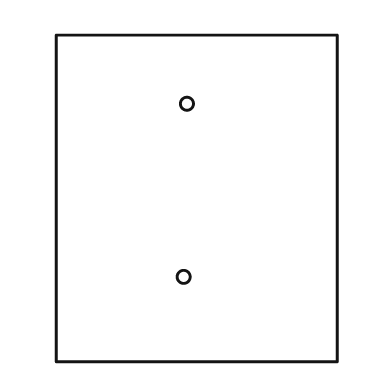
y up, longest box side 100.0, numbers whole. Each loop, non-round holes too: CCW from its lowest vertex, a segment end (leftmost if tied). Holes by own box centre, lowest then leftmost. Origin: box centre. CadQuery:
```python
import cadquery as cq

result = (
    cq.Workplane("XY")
    .moveTo(-43.0, -50.0)
    .lineTo(43.0, -50.0)
    .lineTo(43.0, 50.0)
    .lineTo(-43.0, 50.0)
    .close()
    .moveTo(-4.0, -24.0)
    .circle(2.0)
    .moveTo(-3.0, 29.0)
    .circle(2.0)
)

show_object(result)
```